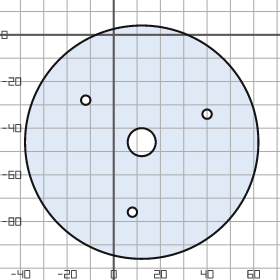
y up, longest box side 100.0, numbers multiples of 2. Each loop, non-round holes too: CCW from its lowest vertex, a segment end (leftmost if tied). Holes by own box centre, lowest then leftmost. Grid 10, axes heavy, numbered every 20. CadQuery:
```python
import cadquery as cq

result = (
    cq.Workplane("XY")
    .moveTo(12.0, -46.0)
    .circle(50.0)
    .moveTo(8.0, -76.0)
    .circle(2.0)
    .moveTo(12.0, -46.0)
    .circle(6.0)
    .moveTo(40.0, -34.0)
    .circle(2.0)
    .moveTo(-12.0, -28.0)
    .circle(2.0)
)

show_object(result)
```